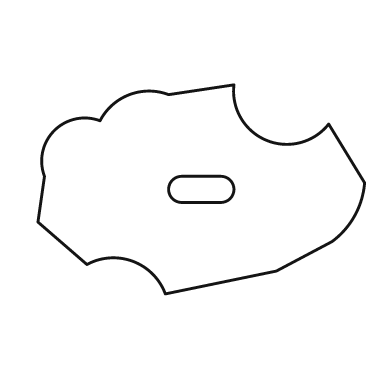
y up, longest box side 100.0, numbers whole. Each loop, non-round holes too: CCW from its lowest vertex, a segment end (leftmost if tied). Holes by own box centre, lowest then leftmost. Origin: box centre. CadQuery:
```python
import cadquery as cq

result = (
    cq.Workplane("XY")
    .moveTo(-11.0, -32.0)
    .lineTo(23.0, -25.0)
    .lineTo(40.0, -16.0)
    .threePointArc((47.0, -8.0), (50.0, 2.0))
    .lineTo(39.0, 20.0)
    .threePointArc((20.0, 15.0), (10.0, 32.0))
    .lineTo(-10.0, 29.0)
    .threePointArc((-22.0, 29.0), (-31.0, 21.0))
    .threePointArc((-45.0, 18.0), (-48.0, 4.0))
    .lineTo(-50.0, -10.0)
    .lineTo(-35.0, -23.0)
    .threePointArc((-21.0, -22.0), (-11.0, -32.0))
    .close()
    .moveTo(-6.0, -4.0)
    .lineTo(6.0, -4.0)
    .threePointArc((10.0, 0.0), (6.0, 4.0))
    .lineTo(-6.0, 4.0)
    .threePointArc((-10.0, 0.0), (-6.0, -4.0))
    .close()
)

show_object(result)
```